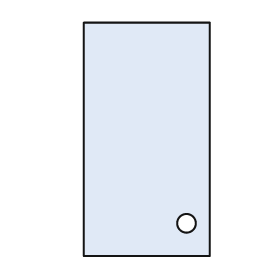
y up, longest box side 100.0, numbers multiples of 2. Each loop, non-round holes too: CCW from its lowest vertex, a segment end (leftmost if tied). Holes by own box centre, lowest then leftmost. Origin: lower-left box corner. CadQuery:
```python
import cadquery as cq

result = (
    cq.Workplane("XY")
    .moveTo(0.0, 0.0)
    .lineTo(54.0, 0.0)
    .lineTo(54.0, 100.0)
    .lineTo(0.0, 100.0)
    .close()
    .moveTo(44.0, 14.0)
    .circle(4.0)
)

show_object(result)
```